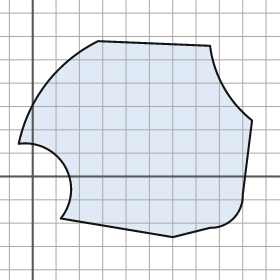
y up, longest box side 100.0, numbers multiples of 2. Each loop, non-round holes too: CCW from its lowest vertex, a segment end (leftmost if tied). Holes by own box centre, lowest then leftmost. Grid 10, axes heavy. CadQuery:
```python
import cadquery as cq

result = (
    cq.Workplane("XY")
    .moveTo(60.0, -26.0)
    .lineTo(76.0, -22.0)
    .threePointArc((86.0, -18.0), (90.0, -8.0))
    .lineTo(94.0, 24.0)
    .threePointArc((82.0, 38.0), (76.0, 56.0))
    .lineTo(28.0, 58.0)
    .threePointArc((6.0, 40.0), (-6.0, 14.0))
    .threePointArc((14.0, 4.0), (12.0, -18.0))
    .close()
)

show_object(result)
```